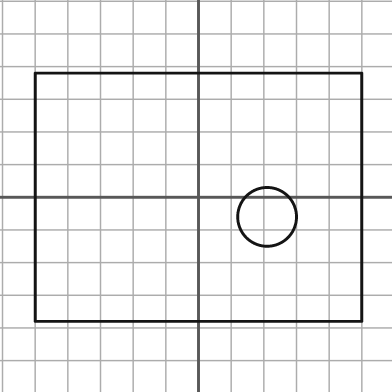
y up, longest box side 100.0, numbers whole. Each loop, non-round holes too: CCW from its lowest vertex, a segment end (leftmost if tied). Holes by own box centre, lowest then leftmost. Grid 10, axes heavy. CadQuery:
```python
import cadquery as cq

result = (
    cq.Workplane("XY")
    .moveTo(-50.0, -38.0)
    .lineTo(50.0, -38.0)
    .lineTo(50.0, 38.0)
    .lineTo(-50.0, 38.0)
    .close()
    .moveTo(21.0, -6.0)
    .circle(9.0)
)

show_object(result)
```